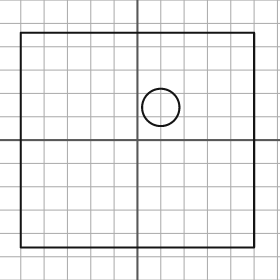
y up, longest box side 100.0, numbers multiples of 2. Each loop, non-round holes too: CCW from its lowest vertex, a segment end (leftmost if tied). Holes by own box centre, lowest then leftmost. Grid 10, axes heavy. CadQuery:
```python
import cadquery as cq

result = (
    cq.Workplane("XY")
    .moveTo(-50.0, -46.0)
    .lineTo(50.0, -46.0)
    .lineTo(50.0, 46.0)
    .lineTo(-50.0, 46.0)
    .close()
    .moveTo(10.0, 14.0)
    .circle(8.0)
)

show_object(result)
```